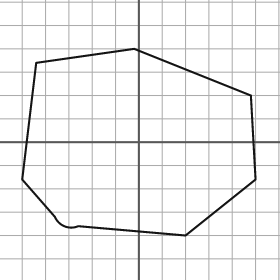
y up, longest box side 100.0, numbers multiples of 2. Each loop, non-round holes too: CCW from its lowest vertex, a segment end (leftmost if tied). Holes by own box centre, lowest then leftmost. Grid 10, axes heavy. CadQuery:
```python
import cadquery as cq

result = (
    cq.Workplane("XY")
    .moveTo(20.0, -40.0)
    .lineTo(50.0, -16.0)
    .lineTo(48.0, 20.0)
    .lineTo(-2.0, 40.0)
    .lineTo(-44.0, 34.0)
    .lineTo(-50.0, -16.0)
    .lineTo(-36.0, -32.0)
    .threePointArc((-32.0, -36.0), (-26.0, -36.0))
    .close()
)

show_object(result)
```